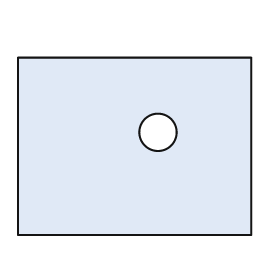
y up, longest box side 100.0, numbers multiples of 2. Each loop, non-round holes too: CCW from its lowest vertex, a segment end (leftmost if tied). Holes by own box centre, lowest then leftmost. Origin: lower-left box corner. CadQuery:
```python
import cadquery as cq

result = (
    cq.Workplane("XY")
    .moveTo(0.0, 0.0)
    .lineTo(100.0, 0.0)
    .lineTo(100.0, 76.0)
    .lineTo(0.0, 76.0)
    .close()
    .moveTo(60.0, 44.0)
    .circle(8.0)
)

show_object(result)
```